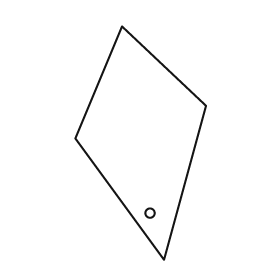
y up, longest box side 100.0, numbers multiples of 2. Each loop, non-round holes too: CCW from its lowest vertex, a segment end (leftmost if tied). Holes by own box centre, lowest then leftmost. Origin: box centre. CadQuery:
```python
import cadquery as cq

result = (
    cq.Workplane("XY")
    .moveTo(10.0, -50.0)
    .lineTo(28.0, 16.0)
    .lineTo(-8.0, 50.0)
    .lineTo(-28.0, 2.0)
    .close()
    .moveTo(4.0, -30.0)
    .circle(2.0)
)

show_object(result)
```